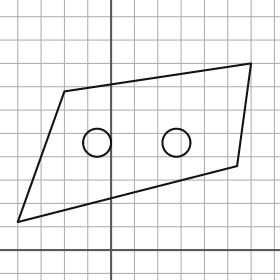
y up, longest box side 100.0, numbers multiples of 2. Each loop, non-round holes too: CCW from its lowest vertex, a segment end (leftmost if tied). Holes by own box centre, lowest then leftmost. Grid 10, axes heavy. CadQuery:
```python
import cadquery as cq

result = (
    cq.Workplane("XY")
    .moveTo(-40.0, 12.0)
    .lineTo(54.0, 36.0)
    .lineTo(60.0, 80.0)
    .lineTo(-20.0, 68.0)
    .close()
    .moveTo(-6.0, 46.0)
    .circle(6.0)
    .moveTo(28.0, 46.0)
    .circle(6.0)
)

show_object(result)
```